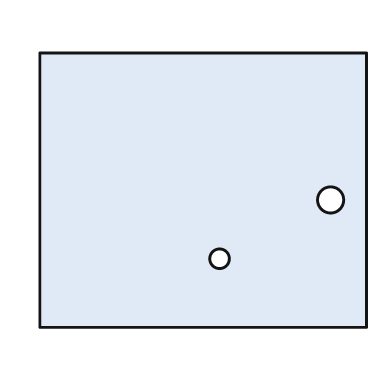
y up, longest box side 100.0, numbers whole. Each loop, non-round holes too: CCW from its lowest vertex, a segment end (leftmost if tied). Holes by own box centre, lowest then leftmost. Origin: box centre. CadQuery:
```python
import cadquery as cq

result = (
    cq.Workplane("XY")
    .moveTo(-50.0, -42.0)
    .lineTo(50.0, -42.0)
    .lineTo(50.0, 42.0)
    .lineTo(-50.0, 42.0)
    .close()
    .moveTo(5.0, -21.0)
    .circle(3.0)
    .moveTo(39.0, -3.0)
    .circle(4.0)
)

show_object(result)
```